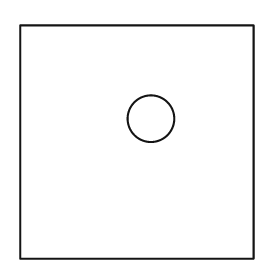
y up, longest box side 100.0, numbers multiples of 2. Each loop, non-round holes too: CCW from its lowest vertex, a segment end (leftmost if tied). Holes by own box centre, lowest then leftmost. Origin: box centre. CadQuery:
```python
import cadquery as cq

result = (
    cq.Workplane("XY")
    .moveTo(-50.0, -50.0)
    .lineTo(50.0, -50.0)
    .lineTo(50.0, 50.0)
    .lineTo(-50.0, 50.0)
    .close()
    .moveTo(6.0, 10.0)
    .circle(10.0)
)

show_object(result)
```